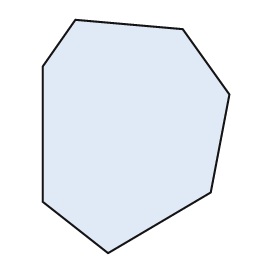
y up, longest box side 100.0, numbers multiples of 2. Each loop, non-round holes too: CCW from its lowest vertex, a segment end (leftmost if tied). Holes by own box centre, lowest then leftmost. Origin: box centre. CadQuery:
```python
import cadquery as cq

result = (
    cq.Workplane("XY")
    .moveTo(-12.0, -50.0)
    .lineTo(32.0, -24.0)
    .lineTo(40.0, 18.0)
    .lineTo(20.0, 46.0)
    .lineTo(-26.0, 50.0)
    .lineTo(-40.0, 30.0)
    .lineTo(-40.0, -28.0)
    .close()
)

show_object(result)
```